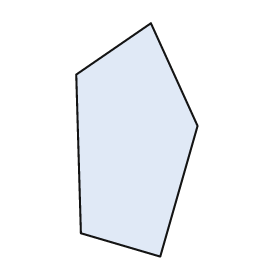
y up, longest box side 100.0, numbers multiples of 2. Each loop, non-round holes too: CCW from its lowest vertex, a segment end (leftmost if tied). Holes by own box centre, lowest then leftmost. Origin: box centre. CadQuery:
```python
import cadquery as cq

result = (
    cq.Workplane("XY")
    .moveTo(10.0, -50.0)
    .lineTo(26.0, 6.0)
    .lineTo(6.0, 50.0)
    .lineTo(-26.0, 28.0)
    .lineTo(-24.0, -40.0)
    .close()
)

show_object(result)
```